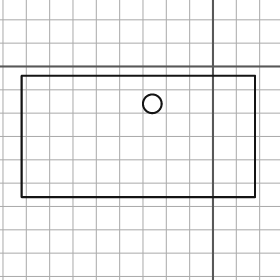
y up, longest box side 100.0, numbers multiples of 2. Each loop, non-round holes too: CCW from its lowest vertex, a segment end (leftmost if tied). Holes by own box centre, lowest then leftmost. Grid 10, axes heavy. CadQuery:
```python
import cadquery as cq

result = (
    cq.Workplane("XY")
    .moveTo(-82.0, -56.0)
    .lineTo(18.0, -56.0)
    .lineTo(18.0, -4.0)
    .lineTo(-82.0, -4.0)
    .close()
    .moveTo(-26.0, -16.0)
    .circle(4.0)
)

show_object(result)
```